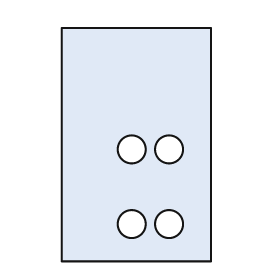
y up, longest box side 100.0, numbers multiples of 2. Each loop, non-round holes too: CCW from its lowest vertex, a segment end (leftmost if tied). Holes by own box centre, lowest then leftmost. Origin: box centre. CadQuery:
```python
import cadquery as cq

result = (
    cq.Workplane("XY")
    .moveTo(-32.0, -50.0)
    .lineTo(32.0, -50.0)
    .lineTo(32.0, 50.0)
    .lineTo(-32.0, 50.0)
    .close()
    .moveTo(-2.0, -34.0)
    .circle(6.0)
    .moveTo(14.0, -34.0)
    .circle(6.0)
    .moveTo(-2.0, -2.0)
    .circle(6.0)
    .moveTo(14.0, -2.0)
    .circle(6.0)
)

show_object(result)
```